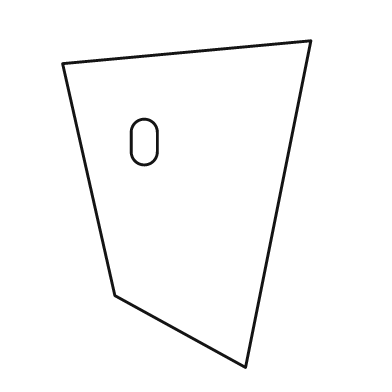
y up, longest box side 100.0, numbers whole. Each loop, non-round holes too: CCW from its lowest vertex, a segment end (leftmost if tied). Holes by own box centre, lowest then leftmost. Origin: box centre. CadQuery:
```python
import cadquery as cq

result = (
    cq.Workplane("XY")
    .moveTo(18.0, -50.0)
    .lineTo(38.0, 50.0)
    .lineTo(-38.0, 43.0)
    .lineTo(-22.0, -28.0)
    .close()
    .moveTo(-17.0, 16.0)
    .threePointArc((-13.0, 12.0), (-9.0, 16.0))
    .lineTo(-9.0, 22.0)
    .threePointArc((-13.0, 26.0), (-17.0, 22.0))
    .close()
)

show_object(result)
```